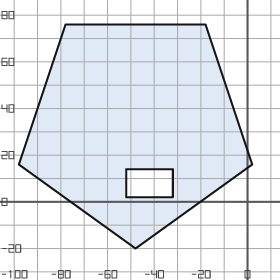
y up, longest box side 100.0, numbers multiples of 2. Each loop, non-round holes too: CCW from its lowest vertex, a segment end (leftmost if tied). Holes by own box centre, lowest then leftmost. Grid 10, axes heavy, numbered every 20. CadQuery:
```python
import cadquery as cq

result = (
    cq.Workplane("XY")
    .moveTo(-48.0, -20.0)
    .lineTo(2.0, 16.0)
    .lineTo(-18.0, 76.0)
    .lineTo(-78.0, 76.0)
    .lineTo(-98.0, 16.0)
    .close()
    .moveTo(-52.0, 2.0)
    .lineTo(-32.0, 2.0)
    .lineTo(-32.0, 14.0)
    .lineTo(-52.0, 14.0)
    .close()
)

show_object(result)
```